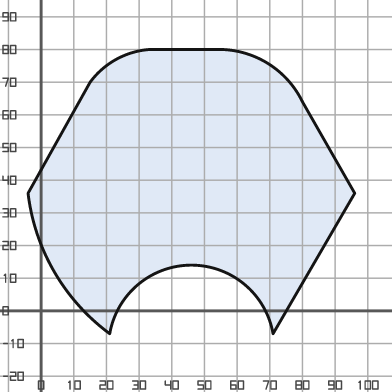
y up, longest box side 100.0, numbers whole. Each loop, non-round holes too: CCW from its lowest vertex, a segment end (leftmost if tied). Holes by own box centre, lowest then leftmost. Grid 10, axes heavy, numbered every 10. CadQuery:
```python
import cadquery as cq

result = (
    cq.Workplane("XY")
    .moveTo(21.0, -7.0)
    .threePointArc((46.0, 14.0), (71.0, -7.0))
    .lineTo(96.0, 36.0)
    .lineTo(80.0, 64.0)
    .threePointArc((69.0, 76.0), (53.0, 80.0))
    .lineTo(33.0, 80.0)
    .threePointArc((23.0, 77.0), (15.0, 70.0))
    .lineTo(-4.0, 36.0)
    .threePointArc((4.0, 12.0), (21.0, -7.0))
    .close()
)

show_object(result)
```